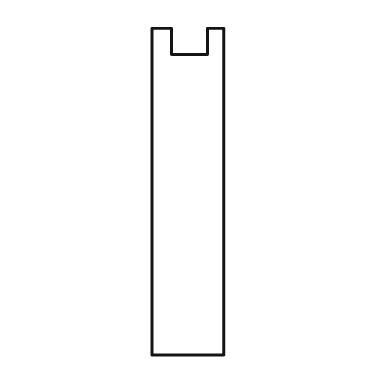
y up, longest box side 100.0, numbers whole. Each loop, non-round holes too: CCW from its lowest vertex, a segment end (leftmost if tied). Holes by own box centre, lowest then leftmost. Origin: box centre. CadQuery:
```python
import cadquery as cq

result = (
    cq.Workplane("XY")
    .moveTo(-11.0, -50.0)
    .lineTo(11.0, -50.0)
    .lineTo(11.0, 50.0)
    .lineTo(6.0, 50.0)
    .lineTo(6.0, 42.0)
    .lineTo(-5.0, 42.0)
    .lineTo(-5.0, 50.0)
    .lineTo(-11.0, 50.0)
    .close()
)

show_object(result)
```